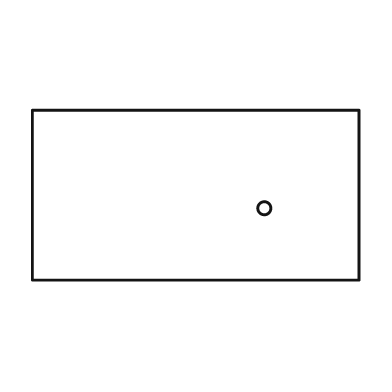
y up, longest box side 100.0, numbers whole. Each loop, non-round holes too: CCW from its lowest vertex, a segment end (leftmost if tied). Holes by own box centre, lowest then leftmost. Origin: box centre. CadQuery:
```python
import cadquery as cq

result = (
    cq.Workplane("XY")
    .moveTo(-50.0, -26.0)
    .lineTo(50.0, -26.0)
    .lineTo(50.0, 26.0)
    .lineTo(-50.0, 26.0)
    .close()
    .moveTo(21.0, -4.0)
    .circle(2.0)
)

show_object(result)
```